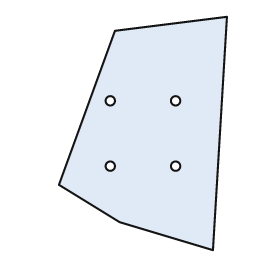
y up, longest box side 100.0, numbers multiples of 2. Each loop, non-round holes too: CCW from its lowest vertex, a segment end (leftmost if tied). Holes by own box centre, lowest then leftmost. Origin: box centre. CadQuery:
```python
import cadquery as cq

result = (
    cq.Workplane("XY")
    .moveTo(30.0, -50.0)
    .lineTo(36.0, 50.0)
    .lineTo(-12.0, 44.0)
    .lineTo(-36.0, -22.0)
    .lineTo(-10.0, -38.0)
    .close()
    .moveTo(-14.0, -14.0)
    .circle(2.0)
    .moveTo(14.0, -14.0)
    .circle(2.0)
    .moveTo(-14.0, 14.0)
    .circle(2.0)
    .moveTo(14.0, 14.0)
    .circle(2.0)
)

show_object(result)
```